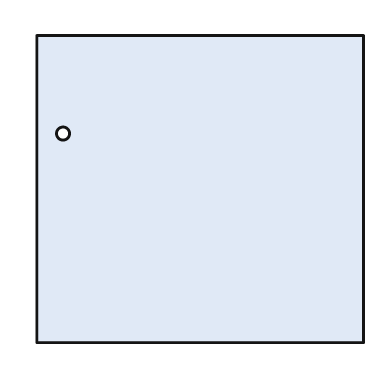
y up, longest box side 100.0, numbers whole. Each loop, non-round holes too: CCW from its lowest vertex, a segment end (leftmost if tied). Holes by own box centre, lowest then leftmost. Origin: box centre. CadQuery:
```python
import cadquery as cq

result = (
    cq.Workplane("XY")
    .moveTo(-50.0, -47.0)
    .lineTo(50.0, -47.0)
    .lineTo(50.0, 47.0)
    .lineTo(-50.0, 47.0)
    .close()
    .moveTo(-42.0, 17.0)
    .circle(2.0)
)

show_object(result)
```